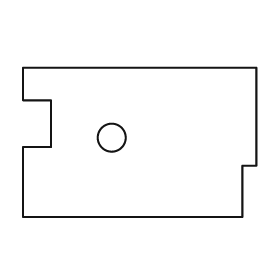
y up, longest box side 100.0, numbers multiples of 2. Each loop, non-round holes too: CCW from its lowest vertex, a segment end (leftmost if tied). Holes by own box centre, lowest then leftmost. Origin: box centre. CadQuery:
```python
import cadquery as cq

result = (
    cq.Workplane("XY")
    .moveTo(-50.0, -32.0)
    .lineTo(44.0, -32.0)
    .lineTo(44.0, -10.0)
    .lineTo(50.0, -10.0)
    .lineTo(50.0, 32.0)
    .lineTo(-50.0, 32.0)
    .lineTo(-50.0, 18.0)
    .lineTo(-38.0, 18.0)
    .lineTo(-38.0, -2.0)
    .lineTo(-50.0, -2.0)
    .close()
    .moveTo(-12.0, 2.0)
    .circle(6.0)
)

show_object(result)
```